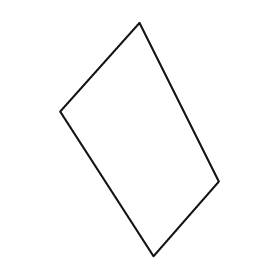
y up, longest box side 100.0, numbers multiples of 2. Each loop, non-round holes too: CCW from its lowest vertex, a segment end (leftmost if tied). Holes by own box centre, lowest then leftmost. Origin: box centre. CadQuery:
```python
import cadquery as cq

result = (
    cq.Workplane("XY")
    .moveTo(6.0, -50.0)
    .lineTo(34.0, -18.0)
    .lineTo(0.0, 50.0)
    .lineTo(-34.0, 12.0)
    .close()
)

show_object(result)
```